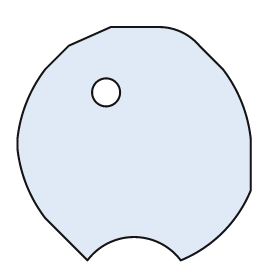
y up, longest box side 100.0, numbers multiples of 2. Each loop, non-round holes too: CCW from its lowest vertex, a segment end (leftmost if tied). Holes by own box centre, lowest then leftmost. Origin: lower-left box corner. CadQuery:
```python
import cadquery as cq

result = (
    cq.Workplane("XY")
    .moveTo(30.0, 0.0)
    .threePointArc((50.0, 10.0), (70.0, 0.0))
    .threePointArc((88.0, 12.0), (100.0, 30.0))
    .lineTo(100.0, 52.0)
    .threePointArc((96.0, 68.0), (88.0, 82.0))
    .lineTo(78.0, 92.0)
    .threePointArc((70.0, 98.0), (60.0, 100.0))
    .lineTo(40.0, 100.0)
    .lineTo(22.0, 92.0)
    .lineTo(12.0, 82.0)
    .threePointArc((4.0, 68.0), (0.0, 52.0))
    .lineTo(0.0, 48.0)
    .threePointArc((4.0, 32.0), (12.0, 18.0))
    .close()
    .moveTo(38.0, 72.0)
    .circle(6.0)
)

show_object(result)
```